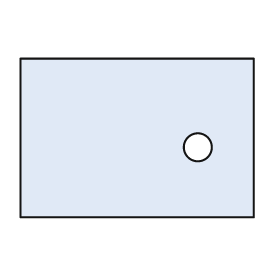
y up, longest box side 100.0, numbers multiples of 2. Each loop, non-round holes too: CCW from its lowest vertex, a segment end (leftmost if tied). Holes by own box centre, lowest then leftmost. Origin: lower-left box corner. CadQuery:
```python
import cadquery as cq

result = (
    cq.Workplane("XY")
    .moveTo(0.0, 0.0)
    .lineTo(100.0, 0.0)
    .lineTo(100.0, 68.0)
    .lineTo(0.0, 68.0)
    .close()
    .moveTo(76.0, 30.0)
    .circle(6.0)
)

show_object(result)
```